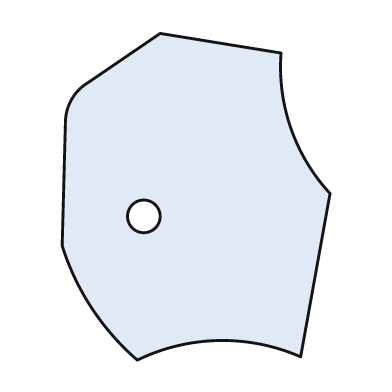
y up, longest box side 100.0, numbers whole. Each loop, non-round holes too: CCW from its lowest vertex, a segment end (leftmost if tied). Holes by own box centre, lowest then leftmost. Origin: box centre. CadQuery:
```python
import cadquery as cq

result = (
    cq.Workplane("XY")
    .moveTo(-18.0, -50.0)
    .threePointArc((7.0, -44.0), (32.0, -49.0))
    .lineTo(41.0, 1.0)
    .threePointArc((29.0, 21.0), (26.0, 44.0))
    .lineTo(-11.0, 50.0)
    .lineTo(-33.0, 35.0)
    .threePointArc((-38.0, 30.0), (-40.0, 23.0))
    .lineTo(-41.0, -15.0)
    .threePointArc((-32.0, -34.0), (-18.0, -50.0))
    .close()
    .moveTo(-16.0, -6.0)
    .circle(5.0)
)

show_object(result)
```